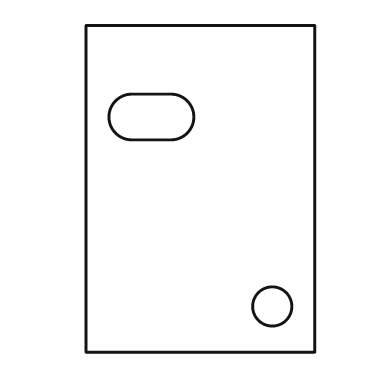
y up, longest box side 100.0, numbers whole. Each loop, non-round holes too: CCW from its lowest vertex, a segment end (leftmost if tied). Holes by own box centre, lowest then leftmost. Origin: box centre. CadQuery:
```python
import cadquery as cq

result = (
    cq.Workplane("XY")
    .moveTo(-35.0, -50.0)
    .lineTo(35.0, -50.0)
    .lineTo(35.0, 50.0)
    .lineTo(-35.0, 50.0)
    .close()
    .moveTo(22.0, -36.0)
    .circle(6.0)
    .moveTo(-21.0, 15.0)
    .lineTo(-9.0, 15.0)
    .threePointArc((-2.0, 22.0), (-9.0, 29.0))
    .lineTo(-21.0, 29.0)
    .threePointArc((-28.0, 22.0), (-21.0, 15.0))
    .close()
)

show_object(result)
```